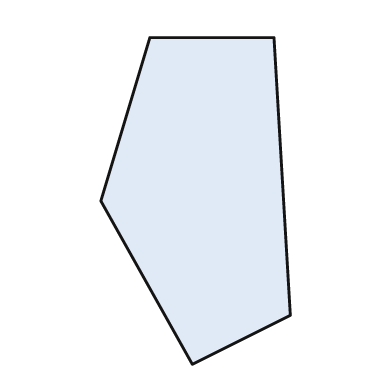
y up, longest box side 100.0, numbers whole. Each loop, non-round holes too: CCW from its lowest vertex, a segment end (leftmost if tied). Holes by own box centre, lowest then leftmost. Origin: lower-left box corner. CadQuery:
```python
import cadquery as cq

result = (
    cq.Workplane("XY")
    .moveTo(28.0, 0.0)
    .lineTo(58.0, 15.0)
    .lineTo(53.0, 100.0)
    .lineTo(15.0, 100.0)
    .lineTo(0.0, 50.0)
    .close()
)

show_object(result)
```